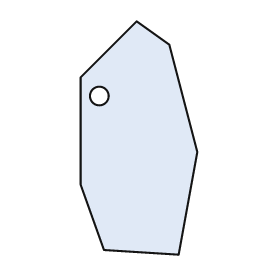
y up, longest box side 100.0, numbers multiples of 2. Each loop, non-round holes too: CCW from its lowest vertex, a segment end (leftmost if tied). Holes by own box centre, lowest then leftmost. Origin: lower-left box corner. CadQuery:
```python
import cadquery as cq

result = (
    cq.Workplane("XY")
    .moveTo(42.0, 0.0)
    .lineTo(50.0, 44.0)
    .lineTo(38.0, 90.0)
    .lineTo(24.0, 100.0)
    .lineTo(0.0, 76.0)
    .lineTo(0.0, 30.0)
    .lineTo(10.0, 2.0)
    .close()
    .moveTo(8.0, 68.0)
    .circle(4.0)
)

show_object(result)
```